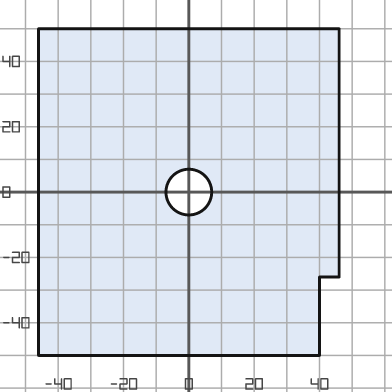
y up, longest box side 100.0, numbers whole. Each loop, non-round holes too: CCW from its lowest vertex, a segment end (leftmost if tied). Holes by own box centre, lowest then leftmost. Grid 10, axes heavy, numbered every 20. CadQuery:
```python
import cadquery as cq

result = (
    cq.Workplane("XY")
    .moveTo(-46.0, -50.0)
    .lineTo(40.0, -50.0)
    .lineTo(40.0, -26.0)
    .lineTo(46.0, -26.0)
    .lineTo(46.0, 50.0)
    .lineTo(-46.0, 50.0)
    .close()
    .moveTo(0.0, 0.0)
    .circle(7.0)
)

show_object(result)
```